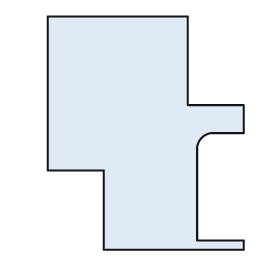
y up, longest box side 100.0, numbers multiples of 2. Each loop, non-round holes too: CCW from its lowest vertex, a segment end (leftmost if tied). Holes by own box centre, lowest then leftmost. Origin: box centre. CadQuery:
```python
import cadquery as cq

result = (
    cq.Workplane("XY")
    .moveTo(-18.0, -50.0)
    .lineTo(42.0, -50.0)
    .lineTo(42.0, -46.0)
    .lineTo(22.0, -46.0)
    .lineTo(22.0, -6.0)
    .threePointArc((24.0, -2.0), (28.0, 0.0))
    .lineTo(42.0, 0.0)
    .lineTo(42.0, 12.0)
    .lineTo(18.0, 12.0)
    .lineTo(18.0, 50.0)
    .lineTo(-42.0, 50.0)
    .lineTo(-42.0, -16.0)
    .lineTo(-18.0, -16.0)
    .close()
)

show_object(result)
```